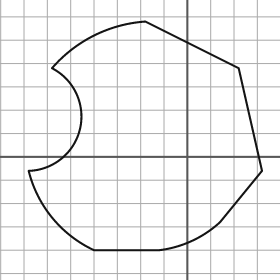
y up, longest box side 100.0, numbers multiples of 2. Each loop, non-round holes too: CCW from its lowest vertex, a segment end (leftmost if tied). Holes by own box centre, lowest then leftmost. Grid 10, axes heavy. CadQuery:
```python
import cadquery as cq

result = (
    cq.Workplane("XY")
    .moveTo(-40.0, -40.0)
    .lineTo(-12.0, -40.0)
    .threePointArc((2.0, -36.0), (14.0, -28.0))
    .lineTo(32.0, -6.0)
    .lineTo(22.0, 38.0)
    .lineTo(-18.0, 58.0)
    .threePointArc((-40.0, 52.0), (-58.0, 38.0))
    .threePointArc((-46.0, 12.0), (-68.0, -6.0))
    .threePointArc((-58.0, -26.0), (-40.0, -40.0))
    .close()
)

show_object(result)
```